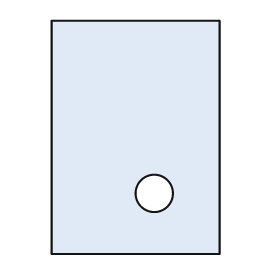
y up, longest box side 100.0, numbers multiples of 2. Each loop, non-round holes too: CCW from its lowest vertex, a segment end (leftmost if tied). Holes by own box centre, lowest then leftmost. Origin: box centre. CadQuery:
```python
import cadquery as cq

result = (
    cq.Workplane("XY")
    .moveTo(-36.0, -50.0)
    .lineTo(36.0, -50.0)
    .lineTo(36.0, 50.0)
    .lineTo(-36.0, 50.0)
    .close()
    .moveTo(8.0, -24.0)
    .circle(8.0)
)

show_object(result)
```